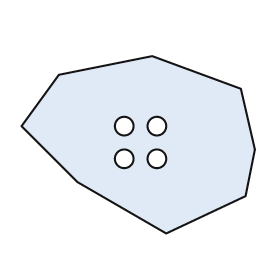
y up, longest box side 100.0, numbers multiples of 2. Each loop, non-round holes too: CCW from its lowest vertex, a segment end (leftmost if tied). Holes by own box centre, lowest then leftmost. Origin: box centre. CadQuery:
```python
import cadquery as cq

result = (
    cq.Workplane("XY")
    .moveTo(12.0, -38.0)
    .lineTo(46.0, -22.0)
    .lineTo(50.0, -2.0)
    .lineTo(44.0, 24.0)
    .lineTo(6.0, 38.0)
    .lineTo(-34.0, 30.0)
    .lineTo(-50.0, 8.0)
    .lineTo(-26.0, -16.0)
    .close()
    .moveTo(-6.0, -6.0)
    .circle(4.0)
    .moveTo(8.0, -6.0)
    .circle(4.0)
    .moveTo(-6.0, 8.0)
    .circle(4.0)
    .moveTo(8.0, 8.0)
    .circle(4.0)
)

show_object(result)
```